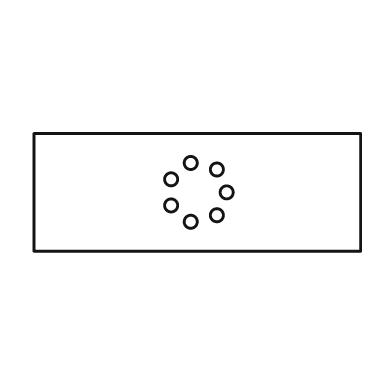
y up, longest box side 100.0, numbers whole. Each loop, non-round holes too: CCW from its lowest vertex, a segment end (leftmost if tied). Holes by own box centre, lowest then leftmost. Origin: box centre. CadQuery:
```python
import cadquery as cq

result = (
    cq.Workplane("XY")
    .moveTo(-50.0, -18.0)
    .lineTo(50.0, -18.0)
    .lineTo(50.0, 18.0)
    .lineTo(-50.0, 18.0)
    .close()
    .moveTo(-2.0, -9.0)
    .circle(2.0)
    .moveTo(6.0, -7.0)
    .circle(2.0)
    .moveTo(-8.0, -4.0)
    .circle(2.0)
    .moveTo(9.0, 0.0)
    .circle(2.0)
    .moveTo(-8.0, 4.0)
    .circle(2.0)
    .moveTo(6.0, 7.0)
    .circle(2.0)
    .moveTo(-2.0, 9.0)
    .circle(2.0)
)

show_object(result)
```